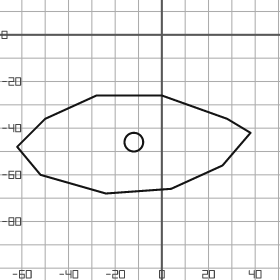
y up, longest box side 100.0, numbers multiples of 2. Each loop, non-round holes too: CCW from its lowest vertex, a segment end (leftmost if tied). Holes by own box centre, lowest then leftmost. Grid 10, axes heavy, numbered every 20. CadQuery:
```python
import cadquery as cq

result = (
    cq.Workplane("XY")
    .moveTo(-24.0, -68.0)
    .lineTo(4.0, -66.0)
    .lineTo(26.0, -56.0)
    .lineTo(38.0, -42.0)
    .lineTo(28.0, -36.0)
    .lineTo(0.0, -26.0)
    .lineTo(-28.0, -26.0)
    .lineTo(-50.0, -36.0)
    .lineTo(-62.0, -48.0)
    .lineTo(-52.0, -60.0)
    .close()
    .moveTo(-12.0, -46.0)
    .circle(4.0)
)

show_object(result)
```